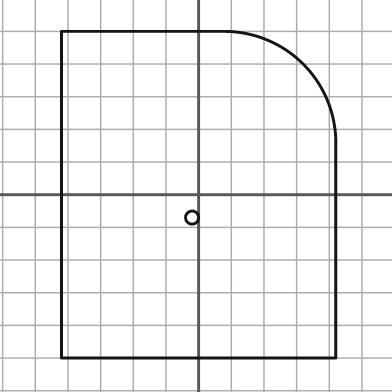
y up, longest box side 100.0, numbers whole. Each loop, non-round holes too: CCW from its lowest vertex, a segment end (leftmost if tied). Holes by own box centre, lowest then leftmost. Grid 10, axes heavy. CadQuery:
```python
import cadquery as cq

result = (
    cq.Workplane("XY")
    .moveTo(-42.0, -50.0)
    .lineTo(42.0, -50.0)
    .lineTo(42.0, 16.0)
    .threePointArc((32.0, 40.0), (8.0, 50.0))
    .lineTo(-42.0, 50.0)
    .close()
    .moveTo(-2.0, -7.0)
    .circle(2.0)
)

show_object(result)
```